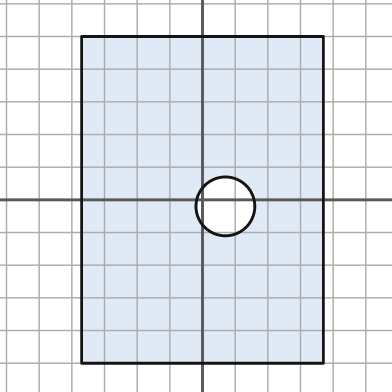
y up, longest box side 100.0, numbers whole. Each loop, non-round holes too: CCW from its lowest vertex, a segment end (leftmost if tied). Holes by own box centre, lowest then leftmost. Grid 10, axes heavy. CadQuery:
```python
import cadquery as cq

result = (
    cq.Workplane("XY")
    .moveTo(-37.0, -50.0)
    .lineTo(37.0, -50.0)
    .lineTo(37.0, 50.0)
    .lineTo(-37.0, 50.0)
    .close()
    .moveTo(7.0, -2.0)
    .circle(9.0)
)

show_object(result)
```